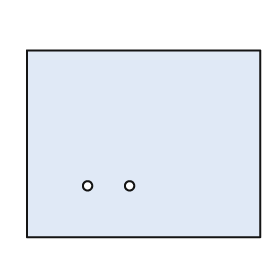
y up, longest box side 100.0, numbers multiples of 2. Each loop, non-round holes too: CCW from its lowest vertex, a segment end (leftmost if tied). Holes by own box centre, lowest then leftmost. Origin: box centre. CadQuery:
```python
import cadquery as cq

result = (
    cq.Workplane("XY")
    .moveTo(-50.0, -40.0)
    .lineTo(50.0, -40.0)
    .lineTo(50.0, 40.0)
    .lineTo(-50.0, 40.0)
    .close()
    .moveTo(-24.0, -18.0)
    .circle(2.0)
    .moveTo(-6.0, -18.0)
    .circle(2.0)
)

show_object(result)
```